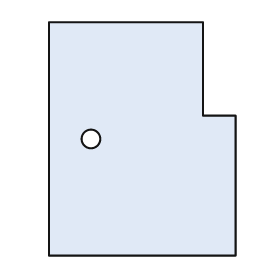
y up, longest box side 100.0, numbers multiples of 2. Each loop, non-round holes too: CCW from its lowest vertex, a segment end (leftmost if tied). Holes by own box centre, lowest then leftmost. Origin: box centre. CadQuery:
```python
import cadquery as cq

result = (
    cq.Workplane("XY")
    .moveTo(-40.0, -50.0)
    .lineTo(40.0, -50.0)
    .lineTo(40.0, 10.0)
    .lineTo(26.0, 10.0)
    .lineTo(26.0, 50.0)
    .lineTo(-40.0, 50.0)
    .close()
    .moveTo(-22.0, 0.0)
    .circle(4.0)
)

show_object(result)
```